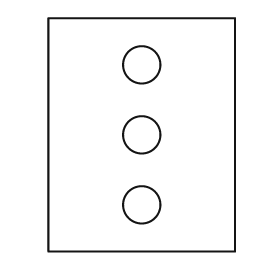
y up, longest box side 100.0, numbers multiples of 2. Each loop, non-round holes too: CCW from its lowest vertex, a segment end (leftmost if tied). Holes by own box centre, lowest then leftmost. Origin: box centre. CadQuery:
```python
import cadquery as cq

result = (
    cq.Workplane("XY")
    .moveTo(-40.0, -50.0)
    .lineTo(40.0, -50.0)
    .lineTo(40.0, 50.0)
    .lineTo(-40.0, 50.0)
    .close()
    .moveTo(0.0, -30.0)
    .circle(8.0)
    .moveTo(0.0, 0.0)
    .circle(8.0)
    .moveTo(0.0, 30.0)
    .circle(8.0)
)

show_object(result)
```